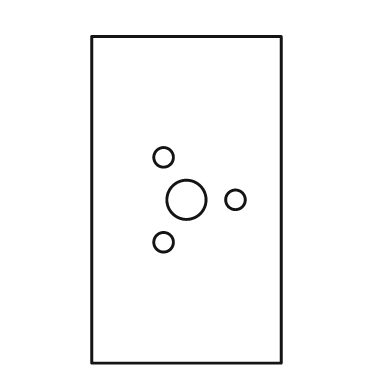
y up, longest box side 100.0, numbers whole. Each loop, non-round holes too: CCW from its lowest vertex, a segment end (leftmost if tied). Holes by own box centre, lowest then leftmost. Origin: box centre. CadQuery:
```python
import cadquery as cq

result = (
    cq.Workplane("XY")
    .moveTo(-29.0, -50.0)
    .lineTo(29.0, -50.0)
    .lineTo(29.0, 50.0)
    .lineTo(-29.0, 50.0)
    .close()
    .moveTo(-7.0, -13.0)
    .circle(3.0)
    .moveTo(0.0, 0.0)
    .circle(6.0)
    .moveTo(15.0, 0.0)
    .circle(3.0)
    .moveTo(-7.0, 13.0)
    .circle(3.0)
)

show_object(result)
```